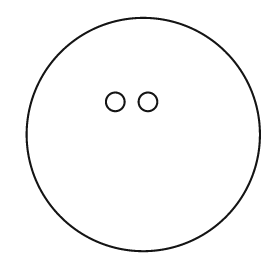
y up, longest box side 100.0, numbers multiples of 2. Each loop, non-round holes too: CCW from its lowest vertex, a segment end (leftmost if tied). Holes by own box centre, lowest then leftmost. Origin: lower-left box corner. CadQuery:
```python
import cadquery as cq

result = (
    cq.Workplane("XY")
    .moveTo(50.0, 50.0)
    .circle(50.0)
    .moveTo(38.0, 64.0)
    .circle(4.0)
    .moveTo(52.0, 64.0)
    .circle(4.0)
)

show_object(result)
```